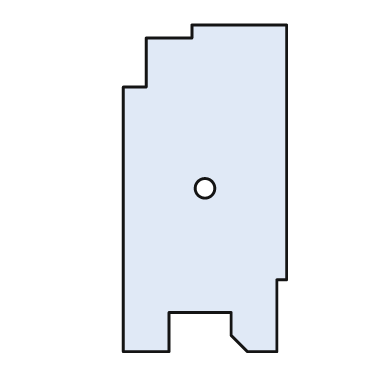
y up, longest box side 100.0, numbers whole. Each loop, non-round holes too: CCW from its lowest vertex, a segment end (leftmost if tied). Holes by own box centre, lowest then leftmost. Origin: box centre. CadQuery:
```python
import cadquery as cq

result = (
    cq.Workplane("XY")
    .moveTo(-25.0, -50.0)
    .lineTo(-11.0, -50.0)
    .lineTo(-11.0, -38.0)
    .lineTo(8.0, -38.0)
    .lineTo(8.0, -45.0)
    .lineTo(13.0, -50.0)
    .lineTo(22.0, -50.0)
    .lineTo(22.0, -28.0)
    .lineTo(25.0, -28.0)
    .lineTo(25.0, 50.0)
    .lineTo(-4.0, 50.0)
    .lineTo(-4.0, 46.0)
    .lineTo(-18.0, 46.0)
    .lineTo(-18.0, 31.0)
    .lineTo(-25.0, 31.0)
    .close()
    .moveTo(0.0, 0.0)
    .circle(3.0)
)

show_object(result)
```